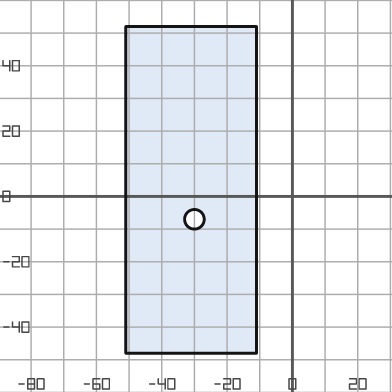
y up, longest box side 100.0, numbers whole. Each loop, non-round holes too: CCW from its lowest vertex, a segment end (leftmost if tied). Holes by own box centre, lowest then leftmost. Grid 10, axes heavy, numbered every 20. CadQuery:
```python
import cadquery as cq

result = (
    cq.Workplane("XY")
    .moveTo(-51.0, -48.0)
    .lineTo(-11.0, -48.0)
    .lineTo(-11.0, 52.0)
    .lineTo(-51.0, 52.0)
    .close()
    .moveTo(-30.0, -7.0)
    .circle(3.0)
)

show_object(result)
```